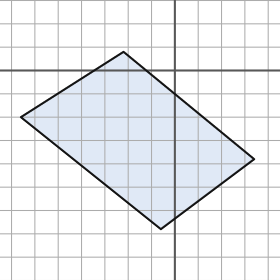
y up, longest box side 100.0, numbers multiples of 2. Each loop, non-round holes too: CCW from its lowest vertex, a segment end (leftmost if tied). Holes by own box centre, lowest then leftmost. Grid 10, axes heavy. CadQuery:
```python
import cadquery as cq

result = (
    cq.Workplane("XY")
    .moveTo(-6.0, -68.0)
    .lineTo(34.0, -38.0)
    .lineTo(-22.0, 8.0)
    .lineTo(-66.0, -20.0)
    .close()
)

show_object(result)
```